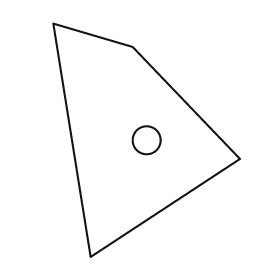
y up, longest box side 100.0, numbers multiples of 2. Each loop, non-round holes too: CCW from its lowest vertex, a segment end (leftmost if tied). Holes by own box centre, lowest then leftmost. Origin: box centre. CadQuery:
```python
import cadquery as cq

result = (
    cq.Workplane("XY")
    .moveTo(-24.0, -50.0)
    .lineTo(40.0, -8.0)
    .lineTo(-6.0, 40.0)
    .lineTo(-40.0, 50.0)
    .close()
    .moveTo(0.0, 0.0)
    .circle(6.0)
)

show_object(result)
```